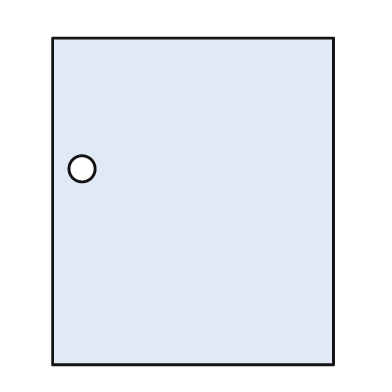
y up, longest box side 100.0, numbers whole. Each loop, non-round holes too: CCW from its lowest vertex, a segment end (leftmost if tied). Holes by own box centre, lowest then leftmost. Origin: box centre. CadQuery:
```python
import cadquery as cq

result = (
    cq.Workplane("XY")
    .moveTo(-43.0, -50.0)
    .lineTo(43.0, -50.0)
    .lineTo(43.0, 50.0)
    .lineTo(-43.0, 50.0)
    .close()
    .moveTo(-34.0, 10.0)
    .circle(4.0)
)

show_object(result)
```